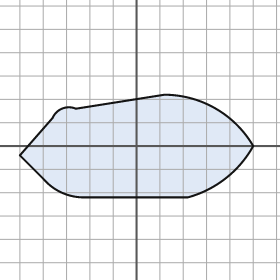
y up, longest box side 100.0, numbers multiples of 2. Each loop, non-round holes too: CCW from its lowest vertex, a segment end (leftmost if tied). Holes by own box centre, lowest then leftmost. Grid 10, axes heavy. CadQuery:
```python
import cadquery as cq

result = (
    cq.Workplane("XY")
    .moveTo(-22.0, -22.0)
    .lineTo(22.0, -22.0)
    .threePointArc((38.0, -14.0), (50.0, 0.0))
    .threePointArc((34.0, 16.0), (12.0, 22.0))
    .lineTo(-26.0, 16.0)
    .threePointArc((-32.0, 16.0), (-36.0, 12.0))
    .lineTo(-50.0, -4.0)
    .lineTo(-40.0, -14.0)
    .threePointArc((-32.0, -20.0), (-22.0, -22.0))
    .close()
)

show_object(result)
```